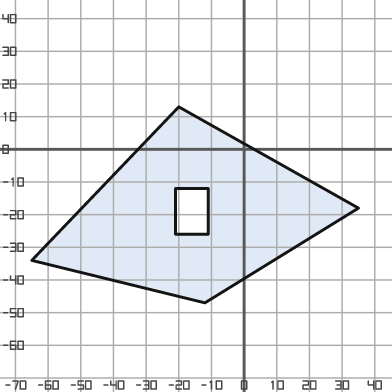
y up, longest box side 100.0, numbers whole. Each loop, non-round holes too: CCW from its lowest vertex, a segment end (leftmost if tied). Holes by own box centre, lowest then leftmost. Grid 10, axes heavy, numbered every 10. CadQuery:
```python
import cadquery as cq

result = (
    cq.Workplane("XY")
    .moveTo(-12.0, -47.0)
    .lineTo(35.0, -18.0)
    .lineTo(-20.0, 13.0)
    .lineTo(-65.0, -34.0)
    .close()
    .moveTo(-21.0, -26.0)
    .lineTo(-11.0, -26.0)
    .lineTo(-11.0, -12.0)
    .lineTo(-21.0, -12.0)
    .close()
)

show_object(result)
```